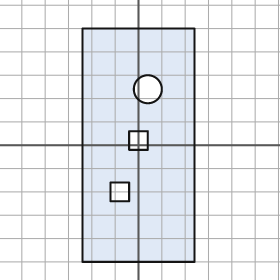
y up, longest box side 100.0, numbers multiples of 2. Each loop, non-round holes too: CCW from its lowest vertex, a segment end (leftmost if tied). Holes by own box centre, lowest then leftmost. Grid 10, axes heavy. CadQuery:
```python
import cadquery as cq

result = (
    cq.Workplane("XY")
    .moveTo(-24.0, -50.0)
    .lineTo(24.0, -50.0)
    .lineTo(24.0, 50.0)
    .lineTo(-24.0, 50.0)
    .close()
    .moveTo(-12.0, -24.0)
    .lineTo(-4.0, -24.0)
    .lineTo(-4.0, -16.0)
    .lineTo(-12.0, -16.0)
    .close()
    .moveTo(-4.0, -2.0)
    .lineTo(4.0, -2.0)
    .lineTo(4.0, 6.0)
    .lineTo(-4.0, 6.0)
    .close()
    .moveTo(4.0, 24.0)
    .circle(6.0)
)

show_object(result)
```